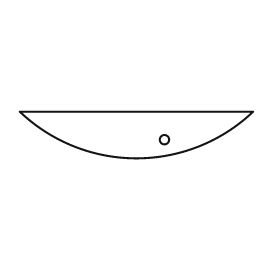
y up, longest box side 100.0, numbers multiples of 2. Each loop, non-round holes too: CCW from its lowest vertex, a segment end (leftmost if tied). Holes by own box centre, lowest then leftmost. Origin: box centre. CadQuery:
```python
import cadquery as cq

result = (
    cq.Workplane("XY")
    .moveTo(-50.0, 10.0)
    .threePointArc((0.0, -10.0), (50.0, 10.0))
    .close()
    .moveTo(12.0, -2.0)
    .circle(2.0)
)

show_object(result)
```